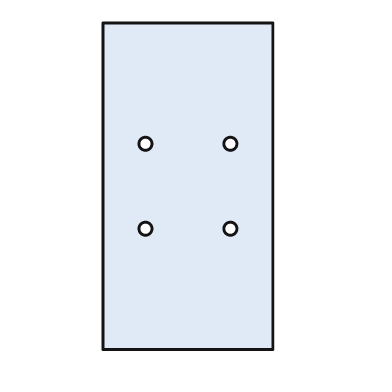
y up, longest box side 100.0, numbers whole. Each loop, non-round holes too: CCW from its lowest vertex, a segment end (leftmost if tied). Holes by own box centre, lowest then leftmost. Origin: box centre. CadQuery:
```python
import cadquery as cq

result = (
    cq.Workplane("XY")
    .moveTo(-26.0, -50.0)
    .lineTo(26.0, -50.0)
    .lineTo(26.0, 50.0)
    .lineTo(-26.0, 50.0)
    .close()
    .moveTo(-13.0, -13.0)
    .circle(2.0)
    .moveTo(13.0, -13.0)
    .circle(2.0)
    .moveTo(-13.0, 13.0)
    .circle(2.0)
    .moveTo(13.0, 13.0)
    .circle(2.0)
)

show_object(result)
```